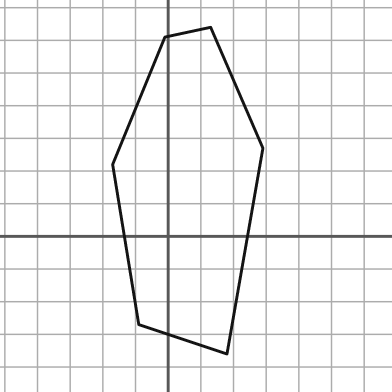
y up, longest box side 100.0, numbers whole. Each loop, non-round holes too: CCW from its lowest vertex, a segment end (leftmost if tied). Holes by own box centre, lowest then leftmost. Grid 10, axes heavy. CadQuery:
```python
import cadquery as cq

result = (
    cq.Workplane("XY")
    .moveTo(18.0, -36.0)
    .lineTo(29.0, 27.0)
    .lineTo(13.0, 64.0)
    .lineTo(-1.0, 61.0)
    .lineTo(-17.0, 22.0)
    .lineTo(-9.0, -27.0)
    .close()
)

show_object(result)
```